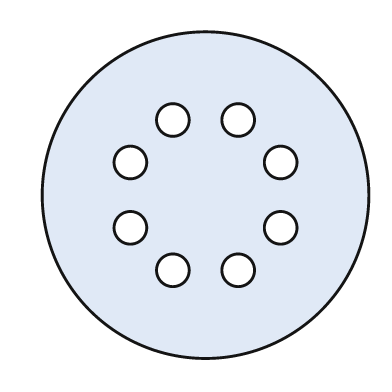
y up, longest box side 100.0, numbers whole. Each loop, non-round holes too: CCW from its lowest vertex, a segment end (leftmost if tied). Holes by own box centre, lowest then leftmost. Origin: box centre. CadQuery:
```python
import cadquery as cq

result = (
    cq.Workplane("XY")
    .moveTo(0.0, 0.0)
    .circle(50.0)
    .moveTo(-10.0, -23.0)
    .circle(5.0)
    .moveTo(10.0, -23.0)
    .circle(5.0)
    .moveTo(-23.0, -10.0)
    .circle(5.0)
    .moveTo(23.0, -10.0)
    .circle(5.0)
    .moveTo(-23.0, 10.0)
    .circle(5.0)
    .moveTo(23.0, 10.0)
    .circle(5.0)
    .moveTo(-10.0, 23.0)
    .circle(5.0)
    .moveTo(10.0, 23.0)
    .circle(5.0)
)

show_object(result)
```